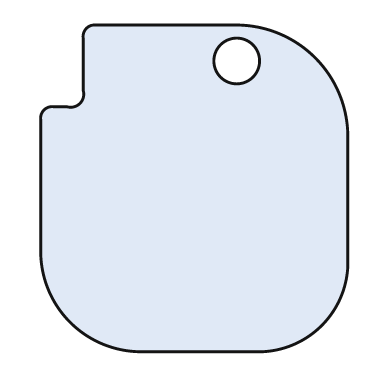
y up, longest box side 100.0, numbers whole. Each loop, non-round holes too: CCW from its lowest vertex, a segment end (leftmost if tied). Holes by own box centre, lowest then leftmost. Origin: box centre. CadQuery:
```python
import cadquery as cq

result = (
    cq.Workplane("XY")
    .moveTo(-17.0, -50.0)
    .lineTo(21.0, -50.0)
    .threePointArc((39.0, -42.0), (47.0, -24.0))
    .lineTo(47.0, 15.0)
    .threePointArc((37.0, 40.0), (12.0, 50.0))
    .lineTo(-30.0, 50.0)
    .threePointArc((-33.0, 49.0), (-34.0, 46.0))
    .lineTo(-34.0, 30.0)
    .threePointArc((-35.0, 26.0), (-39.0, 25.0))
    .lineTo(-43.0, 25.0)
    .threePointArc((-46.0, 24.0), (-47.0, 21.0))
    .lineTo(-47.0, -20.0)
    .threePointArc((-38.0, -41.0), (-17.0, -50.0))
    .close()
    .moveTo(13.0, 39.0)
    .circle(7.0)
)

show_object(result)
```